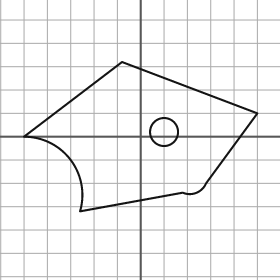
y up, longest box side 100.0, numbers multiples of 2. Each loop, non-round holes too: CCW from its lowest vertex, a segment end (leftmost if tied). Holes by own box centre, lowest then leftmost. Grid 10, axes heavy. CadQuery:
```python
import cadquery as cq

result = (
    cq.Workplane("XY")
    .moveTo(-26.0, -32.0)
    .lineTo(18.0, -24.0)
    .threePointArc((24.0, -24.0), (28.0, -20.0))
    .lineTo(50.0, 10.0)
    .lineTo(-8.0, 32.0)
    .lineTo(-50.0, 0.0)
    .threePointArc((-30.0, -10.0), (-26.0, -32.0))
    .close()
    .moveTo(10.0, 2.0)
    .circle(6.0)
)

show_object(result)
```